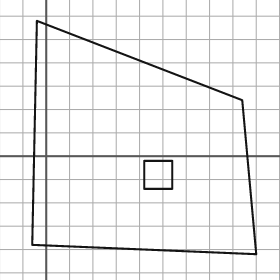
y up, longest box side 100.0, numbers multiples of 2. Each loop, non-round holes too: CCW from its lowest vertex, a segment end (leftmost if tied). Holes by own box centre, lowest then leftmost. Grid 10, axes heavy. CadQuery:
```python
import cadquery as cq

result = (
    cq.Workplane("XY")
    .moveTo(90.0, -42.0)
    .lineTo(84.0, 24.0)
    .lineTo(-4.0, 58.0)
    .lineTo(-6.0, -38.0)
    .close()
    .moveTo(42.0, -14.0)
    .lineTo(54.0, -14.0)
    .lineTo(54.0, -2.0)
    .lineTo(42.0, -2.0)
    .close()
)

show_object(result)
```